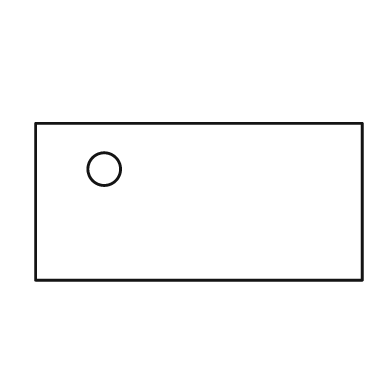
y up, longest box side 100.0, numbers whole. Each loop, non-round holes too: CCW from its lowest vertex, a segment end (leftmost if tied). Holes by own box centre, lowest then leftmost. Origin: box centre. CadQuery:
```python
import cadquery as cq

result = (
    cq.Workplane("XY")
    .moveTo(-50.0, -24.0)
    .lineTo(50.0, -24.0)
    .lineTo(50.0, 24.0)
    .lineTo(-50.0, 24.0)
    .close()
    .moveTo(-29.0, 10.0)
    .circle(5.0)
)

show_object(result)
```